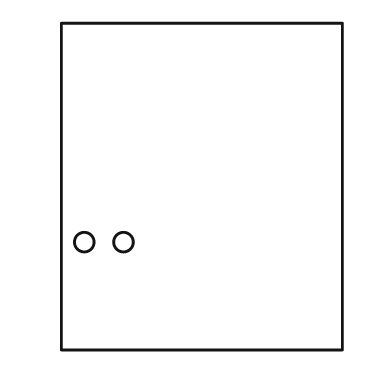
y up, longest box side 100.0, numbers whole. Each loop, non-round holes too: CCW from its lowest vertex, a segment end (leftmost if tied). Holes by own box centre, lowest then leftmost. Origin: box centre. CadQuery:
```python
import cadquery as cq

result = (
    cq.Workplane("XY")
    .moveTo(-43.0, -50.0)
    .lineTo(43.0, -50.0)
    .lineTo(43.0, 50.0)
    .lineTo(-43.0, 50.0)
    .close()
    .moveTo(-36.0, -17.0)
    .circle(3.0)
    .moveTo(-24.0, -17.0)
    .circle(3.0)
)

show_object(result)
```